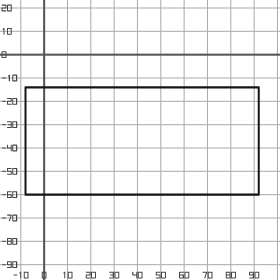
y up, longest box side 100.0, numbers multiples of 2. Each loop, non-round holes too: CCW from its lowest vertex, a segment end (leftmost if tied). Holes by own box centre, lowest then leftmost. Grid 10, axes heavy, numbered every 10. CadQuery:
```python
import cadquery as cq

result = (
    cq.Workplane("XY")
    .moveTo(-8.0, -60.0)
    .lineTo(92.0, -60.0)
    .lineTo(92.0, -14.0)
    .lineTo(-8.0, -14.0)
    .close()
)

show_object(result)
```